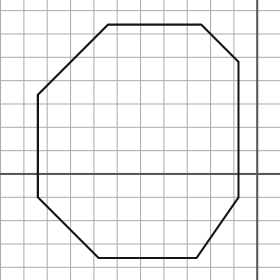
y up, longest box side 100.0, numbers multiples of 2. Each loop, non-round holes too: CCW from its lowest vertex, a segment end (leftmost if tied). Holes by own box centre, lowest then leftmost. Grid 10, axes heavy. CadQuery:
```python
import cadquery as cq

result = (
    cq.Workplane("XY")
    .moveTo(-68.0, -36.0)
    .lineTo(-26.0, -36.0)
    .lineTo(-8.0, -10.0)
    .lineTo(-8.0, 48.0)
    .lineTo(-24.0, 64.0)
    .lineTo(-64.0, 64.0)
    .lineTo(-94.0, 34.0)
    .lineTo(-94.0, -10.0)
    .close()
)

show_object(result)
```